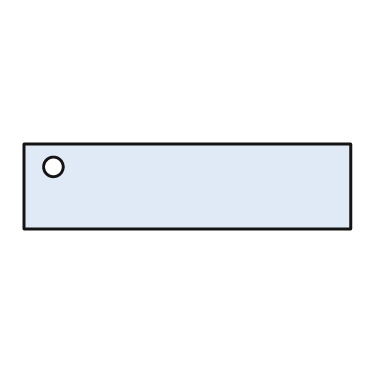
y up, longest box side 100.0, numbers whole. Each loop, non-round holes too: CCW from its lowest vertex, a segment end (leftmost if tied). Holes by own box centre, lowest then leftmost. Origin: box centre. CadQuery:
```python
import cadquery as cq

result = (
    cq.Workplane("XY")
    .moveTo(-50.0, -13.0)
    .lineTo(50.0, -13.0)
    .lineTo(50.0, 13.0)
    .lineTo(-50.0, 13.0)
    .close()
    .moveTo(-41.0, 6.0)
    .circle(3.0)
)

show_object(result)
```